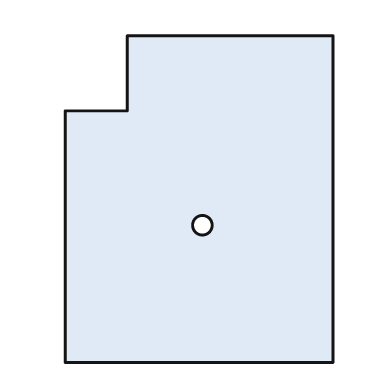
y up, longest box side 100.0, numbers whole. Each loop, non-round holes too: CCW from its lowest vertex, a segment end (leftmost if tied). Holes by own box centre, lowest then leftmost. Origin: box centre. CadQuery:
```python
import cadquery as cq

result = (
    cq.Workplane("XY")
    .moveTo(-41.0, -50.0)
    .lineTo(41.0, -50.0)
    .lineTo(41.0, 50.0)
    .lineTo(-22.0, 50.0)
    .lineTo(-22.0, 27.0)
    .lineTo(-41.0, 27.0)
    .close()
    .moveTo(1.0, -8.0)
    .circle(3.0)
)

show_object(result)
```